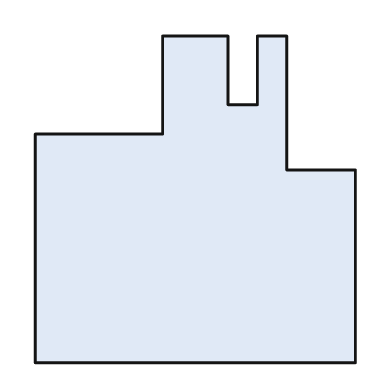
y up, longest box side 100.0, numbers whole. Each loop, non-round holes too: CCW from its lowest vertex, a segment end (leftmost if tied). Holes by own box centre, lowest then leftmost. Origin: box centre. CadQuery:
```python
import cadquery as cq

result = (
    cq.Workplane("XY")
    .moveTo(-49.0, -50.0)
    .lineTo(49.0, -50.0)
    .lineTo(49.0, 9.0)
    .lineTo(28.0, 9.0)
    .lineTo(28.0, 50.0)
    .lineTo(19.0, 50.0)
    .lineTo(19.0, 29.0)
    .lineTo(10.0, 29.0)
    .lineTo(10.0, 50.0)
    .lineTo(-10.0, 50.0)
    .lineTo(-10.0, 20.0)
    .lineTo(-49.0, 20.0)
    .close()
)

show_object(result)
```